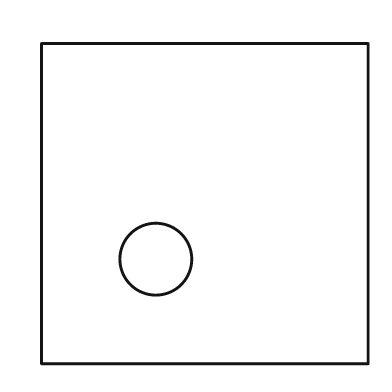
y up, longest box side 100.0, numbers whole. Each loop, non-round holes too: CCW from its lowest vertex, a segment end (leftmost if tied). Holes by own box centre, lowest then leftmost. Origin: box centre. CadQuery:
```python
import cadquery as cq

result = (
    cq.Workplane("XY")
    .moveTo(-50.0, -49.0)
    .lineTo(50.0, -49.0)
    .lineTo(50.0, 49.0)
    .lineTo(-50.0, 49.0)
    .close()
    .moveTo(-15.0, -17.0)
    .circle(11.0)
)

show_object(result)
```